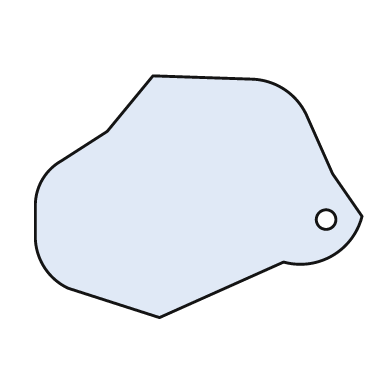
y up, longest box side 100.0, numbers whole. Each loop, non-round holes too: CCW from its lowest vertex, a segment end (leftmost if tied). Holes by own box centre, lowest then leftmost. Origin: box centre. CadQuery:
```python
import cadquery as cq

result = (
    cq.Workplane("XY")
    .moveTo(-12.0, -37.0)
    .lineTo(26.0, -20.0)
    .threePointArc((41.0, -18.0), (50.0, -6.0))
    .lineTo(41.0, 7.0)
    .lineTo(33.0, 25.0)
    .threePointArc((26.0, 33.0), (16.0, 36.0))
    .lineTo(-14.0, 37.0)
    .lineTo(-28.0, 20.0)
    .lineTo(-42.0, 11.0)
    .threePointArc((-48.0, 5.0), (-50.0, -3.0))
    .lineTo(-50.0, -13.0)
    .threePointArc((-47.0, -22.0), (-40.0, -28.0))
    .close()
    .moveTo(39.0, -7.0)
    .circle(3.0)
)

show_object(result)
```